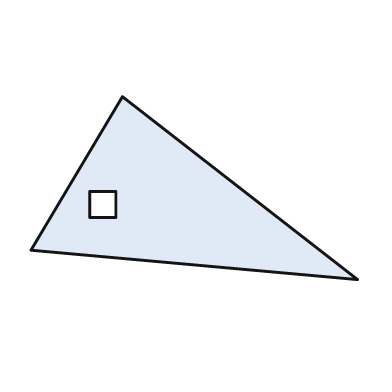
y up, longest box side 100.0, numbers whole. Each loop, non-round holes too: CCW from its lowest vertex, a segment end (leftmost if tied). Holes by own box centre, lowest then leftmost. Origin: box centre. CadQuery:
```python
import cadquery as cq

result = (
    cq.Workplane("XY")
    .moveTo(50.0, -28.0)
    .lineTo(-22.0, 28.0)
    .lineTo(-50.0, -19.0)
    .close()
    .moveTo(-32.0, -9.0)
    .lineTo(-24.0, -9.0)
    .lineTo(-24.0, -1.0)
    .lineTo(-32.0, -1.0)
    .close()
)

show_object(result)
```